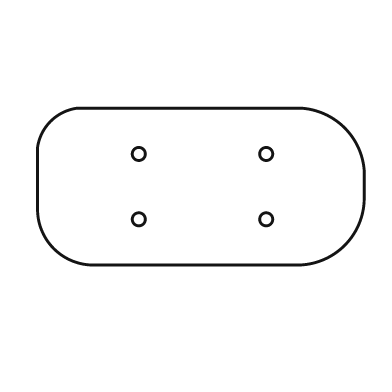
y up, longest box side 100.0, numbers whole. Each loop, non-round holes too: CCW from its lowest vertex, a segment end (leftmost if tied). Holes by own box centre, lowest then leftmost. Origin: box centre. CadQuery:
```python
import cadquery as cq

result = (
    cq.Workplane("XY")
    .moveTo(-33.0, -24.0)
    .lineTo(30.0, -24.0)
    .threePointArc((44.0, -18.0), (50.0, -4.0))
    .lineTo(50.0, 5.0)
    .threePointArc((44.0, 18.0), (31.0, 24.0))
    .lineTo(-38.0, 24.0)
    .threePointArc((-46.0, 20.0), (-50.0, 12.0))
    .lineTo(-50.0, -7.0)
    .threePointArc((-45.0, -19.0), (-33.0, -24.0))
    .close()
    .moveTo(-19.0, -10.0)
    .circle(2.0)
    .moveTo(20.0, -10.0)
    .circle(2.0)
    .moveTo(-19.0, 10.0)
    .circle(2.0)
    .moveTo(20.0, 10.0)
    .circle(2.0)
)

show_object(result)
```